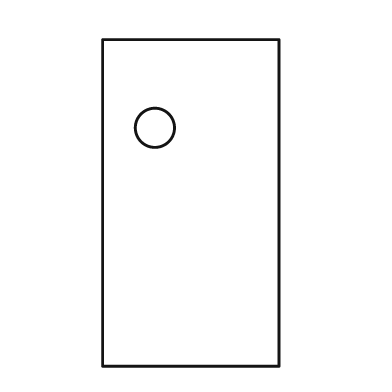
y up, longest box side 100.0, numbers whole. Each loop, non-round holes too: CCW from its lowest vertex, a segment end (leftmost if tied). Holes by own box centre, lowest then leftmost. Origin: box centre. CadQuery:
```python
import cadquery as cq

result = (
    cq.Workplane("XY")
    .moveTo(-27.0, -50.0)
    .lineTo(27.0, -50.0)
    .lineTo(27.0, 50.0)
    .lineTo(-27.0, 50.0)
    .close()
    .moveTo(-11.0, 23.0)
    .circle(6.0)
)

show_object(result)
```